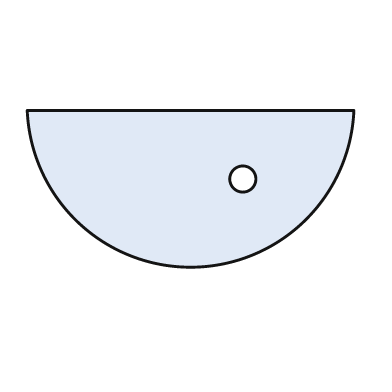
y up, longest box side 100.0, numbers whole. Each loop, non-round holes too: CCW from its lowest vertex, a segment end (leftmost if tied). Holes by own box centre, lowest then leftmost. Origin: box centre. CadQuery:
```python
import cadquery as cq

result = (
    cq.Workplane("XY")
    .moveTo(-50.0, 24.0)
    .threePointArc((0.0, -24.0), (50.0, 24.0))
    .close()
    .moveTo(16.0, 3.0)
    .circle(4.0)
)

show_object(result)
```